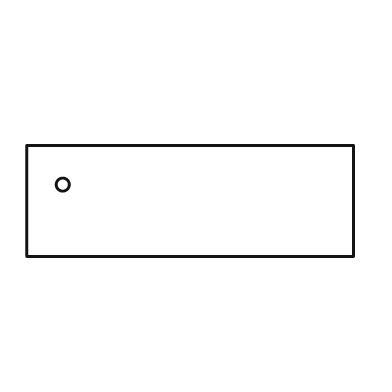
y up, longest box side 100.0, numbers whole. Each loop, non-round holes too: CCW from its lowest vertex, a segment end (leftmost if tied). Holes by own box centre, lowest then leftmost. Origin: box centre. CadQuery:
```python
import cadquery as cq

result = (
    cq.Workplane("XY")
    .moveTo(-50.0, -17.0)
    .lineTo(50.0, -17.0)
    .lineTo(50.0, 17.0)
    .lineTo(-50.0, 17.0)
    .close()
    .moveTo(-39.0, 5.0)
    .circle(2.0)
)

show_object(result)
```